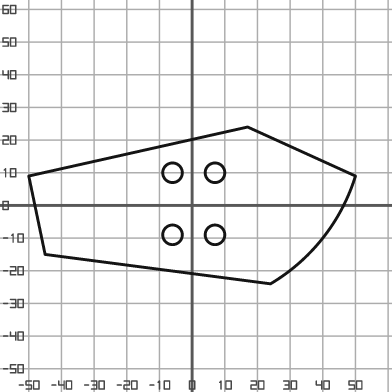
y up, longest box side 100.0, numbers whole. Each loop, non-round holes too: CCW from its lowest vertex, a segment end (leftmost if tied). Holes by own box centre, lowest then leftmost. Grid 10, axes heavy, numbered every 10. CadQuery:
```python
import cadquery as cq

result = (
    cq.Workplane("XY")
    .moveTo(24.0, -24.0)
    .threePointArc((40.0, -10.0), (50.0, 9.0))
    .lineTo(17.0, 24.0)
    .lineTo(-50.0, 9.0)
    .lineTo(-45.0, -15.0)
    .close()
    .moveTo(-6.0, -9.0)
    .circle(3.0)
    .moveTo(7.0, -9.0)
    .circle(3.0)
    .moveTo(-6.0, 10.0)
    .circle(3.0)
    .moveTo(7.0, 10.0)
    .circle(3.0)
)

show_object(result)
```